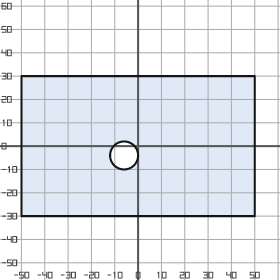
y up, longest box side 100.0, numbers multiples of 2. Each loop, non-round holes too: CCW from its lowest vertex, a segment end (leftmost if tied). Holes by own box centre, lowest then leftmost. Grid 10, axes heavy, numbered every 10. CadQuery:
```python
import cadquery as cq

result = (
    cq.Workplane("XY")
    .moveTo(-50.0, -30.0)
    .lineTo(50.0, -30.0)
    .lineTo(50.0, 30.0)
    .lineTo(-50.0, 30.0)
    .close()
    .moveTo(-6.0, -4.0)
    .circle(6.0)
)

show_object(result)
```